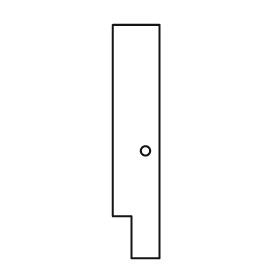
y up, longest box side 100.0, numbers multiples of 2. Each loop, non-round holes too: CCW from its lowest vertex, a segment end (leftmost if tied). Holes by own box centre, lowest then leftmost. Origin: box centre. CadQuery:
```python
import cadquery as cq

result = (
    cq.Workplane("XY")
    .moveTo(-2.0, -50.0)
    .lineTo(10.0, -50.0)
    .lineTo(10.0, 50.0)
    .lineTo(-10.0, 50.0)
    .lineTo(-10.0, -32.0)
    .lineTo(-2.0, -32.0)
    .close()
    .moveTo(4.0, -4.0)
    .circle(2.0)
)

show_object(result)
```